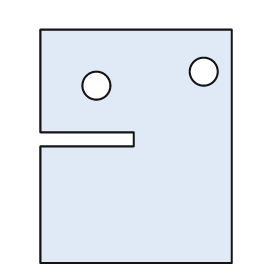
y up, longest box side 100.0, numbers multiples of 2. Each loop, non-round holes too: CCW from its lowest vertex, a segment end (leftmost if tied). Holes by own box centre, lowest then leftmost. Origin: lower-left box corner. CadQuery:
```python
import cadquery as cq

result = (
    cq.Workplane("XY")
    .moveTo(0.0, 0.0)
    .lineTo(82.0, 0.0)
    .lineTo(82.0, 100.0)
    .lineTo(0.0, 100.0)
    .lineTo(0.0, 56.0)
    .lineTo(40.0, 56.0)
    .lineTo(40.0, 50.0)
    .lineTo(0.0, 50.0)
    .close()
    .moveTo(24.0, 76.0)
    .circle(6.0)
    .moveTo(70.0, 82.0)
    .circle(6.0)
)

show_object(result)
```